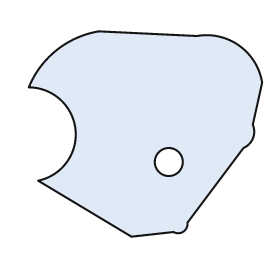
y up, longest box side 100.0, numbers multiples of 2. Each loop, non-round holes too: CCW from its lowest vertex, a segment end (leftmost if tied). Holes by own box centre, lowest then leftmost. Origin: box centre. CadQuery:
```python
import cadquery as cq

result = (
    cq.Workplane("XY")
    .moveTo(-6.0, -44.0)
    .lineTo(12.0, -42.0)
    .threePointArc((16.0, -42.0), (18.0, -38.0))
    .lineTo(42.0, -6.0)
    .threePointArc((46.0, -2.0), (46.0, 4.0))
    .lineTo(50.0, 22.0)
    .threePointArc((40.0, 38.0), (22.0, 42.0))
    .lineTo(-20.0, 44.0)
    .threePointArc((-38.0, 36.0), (-50.0, 20.0))
    .threePointArc((-30.0, 2.0), (-46.0, -20.0))
    .close()
    .moveTo(10.0, -12.0)
    .circle(6.0)
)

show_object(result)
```